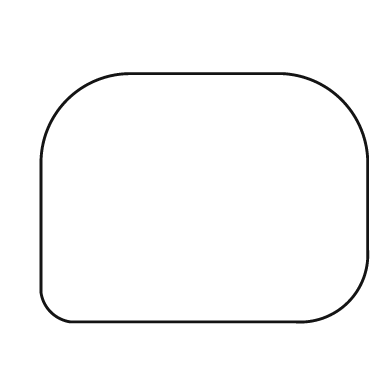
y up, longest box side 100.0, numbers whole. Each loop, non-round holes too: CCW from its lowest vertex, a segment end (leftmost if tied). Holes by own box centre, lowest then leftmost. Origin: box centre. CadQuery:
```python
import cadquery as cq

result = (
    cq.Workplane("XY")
    .moveTo(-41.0, -38.0)
    .lineTo(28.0, -38.0)
    .threePointArc((44.0, -32.0), (50.0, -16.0))
    .lineTo(50.0, 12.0)
    .threePointArc((42.0, 30.0), (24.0, 38.0))
    .lineTo(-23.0, 38.0)
    .threePointArc((-42.0, 30.0), (-50.0, 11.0))
    .lineTo(-50.0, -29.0)
    .threePointArc((-47.0, -35.0), (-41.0, -38.0))
    .close()
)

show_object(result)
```